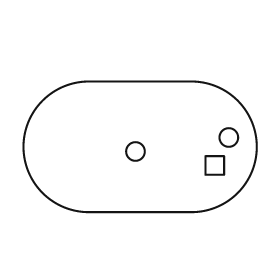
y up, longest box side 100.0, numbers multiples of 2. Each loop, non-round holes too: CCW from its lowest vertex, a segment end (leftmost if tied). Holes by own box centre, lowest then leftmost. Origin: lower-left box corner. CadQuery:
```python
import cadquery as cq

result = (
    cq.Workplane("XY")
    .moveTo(28.0, 0.0)
    .lineTo(72.0, 0.0)
    .threePointArc((100.0, 28.0), (72.0, 56.0))
    .lineTo(28.0, 56.0)
    .threePointArc((0.0, 28.0), (28.0, 0.0))
    .close()
    .moveTo(78.0, 16.0)
    .lineTo(86.0, 16.0)
    .lineTo(86.0, 24.0)
    .lineTo(78.0, 24.0)
    .close()
    .moveTo(48.0, 26.0)
    .circle(4.0)
    .moveTo(88.0, 32.0)
    .circle(4.0)
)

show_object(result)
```